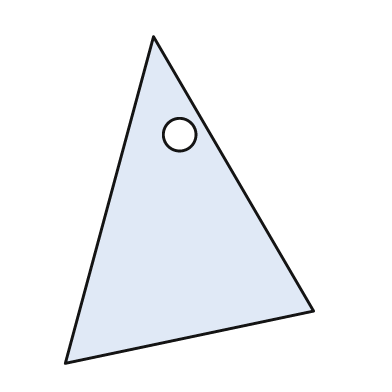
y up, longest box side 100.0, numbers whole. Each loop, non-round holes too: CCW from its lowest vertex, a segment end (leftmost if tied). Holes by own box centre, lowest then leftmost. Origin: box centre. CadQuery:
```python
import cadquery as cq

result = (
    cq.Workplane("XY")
    .moveTo(-38.0, -50.0)
    .lineTo(38.0, -34.0)
    .lineTo(-11.0, 50.0)
    .close()
    .moveTo(-3.0, 20.0)
    .circle(5.0)
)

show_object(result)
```